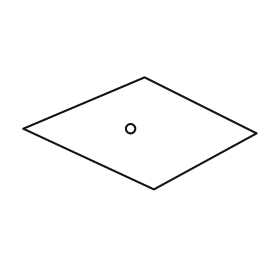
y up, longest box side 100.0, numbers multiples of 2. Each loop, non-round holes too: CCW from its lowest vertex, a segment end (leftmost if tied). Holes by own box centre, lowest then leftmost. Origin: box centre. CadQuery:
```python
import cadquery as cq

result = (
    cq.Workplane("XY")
    .moveTo(6.0, -24.0)
    .lineTo(50.0, 0.0)
    .lineTo(2.0, 24.0)
    .lineTo(-50.0, 2.0)
    .close()
    .moveTo(-4.0, 2.0)
    .circle(2.0)
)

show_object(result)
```